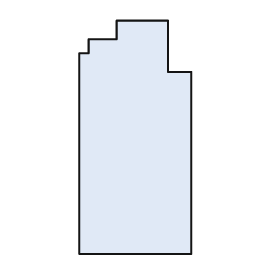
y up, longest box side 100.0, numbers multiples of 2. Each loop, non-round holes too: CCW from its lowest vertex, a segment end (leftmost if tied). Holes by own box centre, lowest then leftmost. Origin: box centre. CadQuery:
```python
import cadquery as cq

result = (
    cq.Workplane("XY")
    .moveTo(-24.0, -50.0)
    .lineTo(24.0, -50.0)
    .lineTo(24.0, 28.0)
    .lineTo(14.0, 28.0)
    .lineTo(14.0, 50.0)
    .lineTo(-8.0, 50.0)
    .lineTo(-8.0, 42.0)
    .lineTo(-20.0, 42.0)
    .lineTo(-20.0, 36.0)
    .lineTo(-24.0, 36.0)
    .close()
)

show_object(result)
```